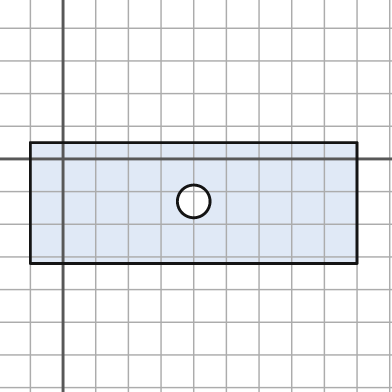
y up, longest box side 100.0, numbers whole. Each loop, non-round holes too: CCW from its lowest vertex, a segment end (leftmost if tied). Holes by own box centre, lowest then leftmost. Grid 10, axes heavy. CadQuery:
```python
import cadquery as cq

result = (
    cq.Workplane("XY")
    .moveTo(-10.0, -32.0)
    .lineTo(90.0, -32.0)
    .lineTo(90.0, 5.0)
    .lineTo(-10.0, 5.0)
    .close()
    .moveTo(40.0, -13.0)
    .circle(5.0)
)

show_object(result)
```